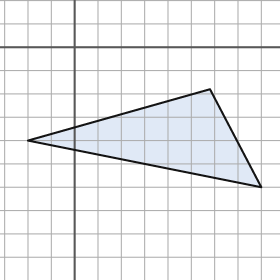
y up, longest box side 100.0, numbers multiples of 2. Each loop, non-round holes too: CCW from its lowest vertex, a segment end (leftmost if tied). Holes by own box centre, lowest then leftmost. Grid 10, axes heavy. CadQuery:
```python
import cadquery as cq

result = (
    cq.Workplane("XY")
    .moveTo(80.0, -60.0)
    .lineTo(58.0, -18.0)
    .lineTo(-20.0, -40.0)
    .close()
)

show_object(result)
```